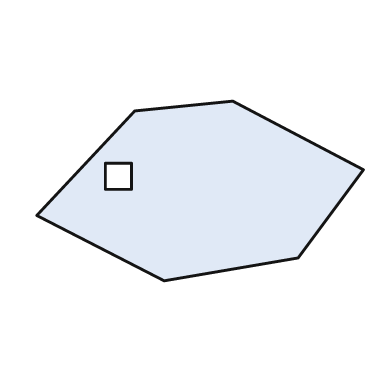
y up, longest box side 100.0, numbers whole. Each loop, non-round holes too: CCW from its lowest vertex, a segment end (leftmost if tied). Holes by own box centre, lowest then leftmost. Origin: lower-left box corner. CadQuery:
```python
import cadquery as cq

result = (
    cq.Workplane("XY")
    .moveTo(39.0, 0.0)
    .lineTo(80.0, 7.0)
    .lineTo(100.0, 34.0)
    .lineTo(60.0, 55.0)
    .lineTo(30.0, 52.0)
    .lineTo(0.0, 20.0)
    .close()
    .moveTo(21.0, 28.0)
    .lineTo(29.0, 28.0)
    .lineTo(29.0, 36.0)
    .lineTo(21.0, 36.0)
    .close()
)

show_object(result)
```